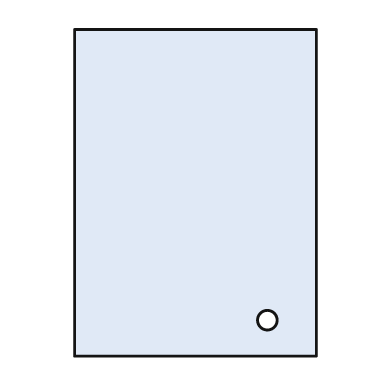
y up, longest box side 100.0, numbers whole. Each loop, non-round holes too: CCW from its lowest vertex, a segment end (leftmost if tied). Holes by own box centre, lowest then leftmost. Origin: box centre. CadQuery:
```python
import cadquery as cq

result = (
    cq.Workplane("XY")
    .moveTo(-37.0, -50.0)
    .lineTo(37.0, -50.0)
    .lineTo(37.0, 50.0)
    .lineTo(-37.0, 50.0)
    .close()
    .moveTo(22.0, -39.0)
    .circle(3.0)
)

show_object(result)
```